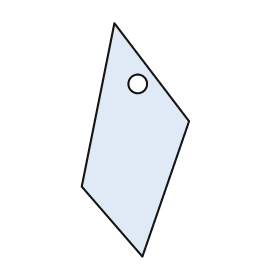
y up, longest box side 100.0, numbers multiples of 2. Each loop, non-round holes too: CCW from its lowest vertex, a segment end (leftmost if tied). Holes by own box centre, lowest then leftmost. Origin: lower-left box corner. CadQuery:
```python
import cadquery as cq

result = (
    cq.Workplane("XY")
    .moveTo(26.0, 0.0)
    .lineTo(46.0, 58.0)
    .lineTo(14.0, 100.0)
    .lineTo(0.0, 30.0)
    .close()
    .moveTo(24.0, 74.0)
    .circle(4.0)
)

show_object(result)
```